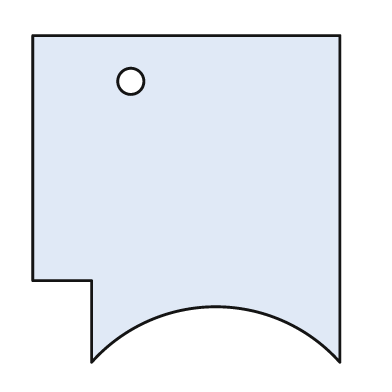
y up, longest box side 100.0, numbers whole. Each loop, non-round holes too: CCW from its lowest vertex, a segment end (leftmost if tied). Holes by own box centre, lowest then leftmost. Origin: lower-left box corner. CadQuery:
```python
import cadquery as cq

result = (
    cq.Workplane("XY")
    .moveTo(18.0, 0.0)
    .threePointArc((56.0, 17.0), (94.0, 0.0))
    .lineTo(94.0, 100.0)
    .lineTo(0.0, 100.0)
    .lineTo(0.0, 25.0)
    .lineTo(18.0, 25.0)
    .close()
    .moveTo(30.0, 86.0)
    .circle(4.0)
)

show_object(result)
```